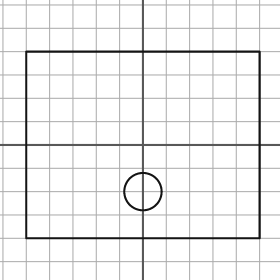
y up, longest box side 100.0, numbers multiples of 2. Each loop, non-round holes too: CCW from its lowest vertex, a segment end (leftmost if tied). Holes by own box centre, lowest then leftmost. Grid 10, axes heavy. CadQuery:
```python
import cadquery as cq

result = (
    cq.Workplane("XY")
    .moveTo(-50.0, -40.0)
    .lineTo(50.0, -40.0)
    .lineTo(50.0, 40.0)
    .lineTo(-50.0, 40.0)
    .close()
    .moveTo(0.0, -20.0)
    .circle(8.0)
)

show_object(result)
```